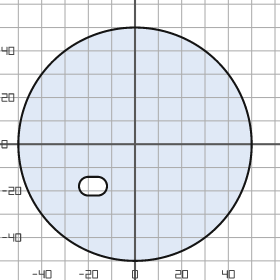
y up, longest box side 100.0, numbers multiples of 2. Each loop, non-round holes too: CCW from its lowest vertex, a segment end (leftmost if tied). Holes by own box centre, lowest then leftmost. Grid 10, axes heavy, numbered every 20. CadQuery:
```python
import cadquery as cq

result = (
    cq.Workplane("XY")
    .moveTo(0.0, 0.0)
    .circle(50.0)
    .moveTo(-20.0, -22.0)
    .lineTo(-16.0, -22.0)
    .threePointArc((-12.0, -18.0), (-16.0, -14.0))
    .lineTo(-20.0, -14.0)
    .threePointArc((-24.0, -18.0), (-20.0, -22.0))
    .close()
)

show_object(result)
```